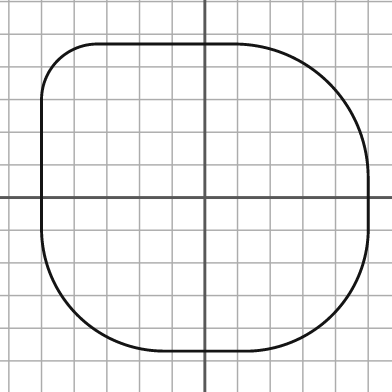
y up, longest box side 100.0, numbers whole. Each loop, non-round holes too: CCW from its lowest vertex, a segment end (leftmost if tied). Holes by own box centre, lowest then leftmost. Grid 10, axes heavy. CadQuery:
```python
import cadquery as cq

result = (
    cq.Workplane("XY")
    .moveTo(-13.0, -47.0)
    .lineTo(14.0, -47.0)
    .threePointArc((39.0, -36.0), (50.0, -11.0))
    .lineTo(50.0, 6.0)
    .threePointArc((38.0, 35.0), (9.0, 47.0))
    .lineTo(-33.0, 47.0)
    .threePointArc((-45.0, 42.0), (-50.0, 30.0))
    .lineTo(-50.0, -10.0)
    .threePointArc((-39.0, -36.0), (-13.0, -47.0))
    .close()
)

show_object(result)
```